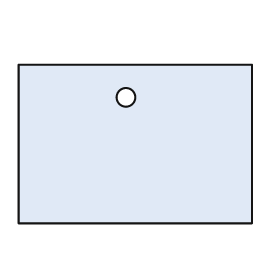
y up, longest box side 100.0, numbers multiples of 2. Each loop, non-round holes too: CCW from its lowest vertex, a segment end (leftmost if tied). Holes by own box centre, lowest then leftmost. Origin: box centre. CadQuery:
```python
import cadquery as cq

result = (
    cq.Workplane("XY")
    .moveTo(-50.0, -34.0)
    .lineTo(50.0, -34.0)
    .lineTo(50.0, 34.0)
    .lineTo(-50.0, 34.0)
    .close()
    .moveTo(-4.0, 20.0)
    .circle(4.0)
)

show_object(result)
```